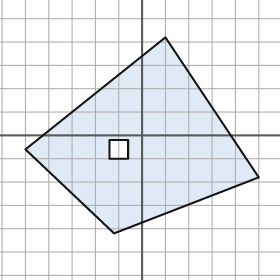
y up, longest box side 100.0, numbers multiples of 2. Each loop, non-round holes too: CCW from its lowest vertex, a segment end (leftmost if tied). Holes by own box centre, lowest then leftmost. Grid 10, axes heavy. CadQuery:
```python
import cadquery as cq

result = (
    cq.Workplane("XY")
    .moveTo(-12.0, -42.0)
    .lineTo(50.0, -18.0)
    .lineTo(10.0, 42.0)
    .lineTo(-50.0, -6.0)
    .close()
    .moveTo(-14.0, -10.0)
    .lineTo(-6.0, -10.0)
    .lineTo(-6.0, -2.0)
    .lineTo(-14.0, -2.0)
    .close()
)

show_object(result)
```